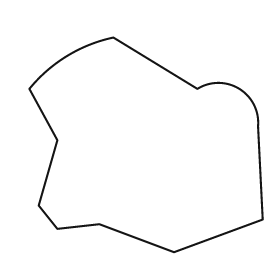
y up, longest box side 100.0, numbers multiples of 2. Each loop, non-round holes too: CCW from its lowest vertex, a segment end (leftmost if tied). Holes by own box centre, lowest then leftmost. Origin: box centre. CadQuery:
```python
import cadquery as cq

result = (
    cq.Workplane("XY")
    .moveTo(12.0, -46.0)
    .lineTo(50.0, -32.0)
    .lineTo(48.0, 8.0)
    .threePointArc((40.0, 24.0), (22.0, 24.0))
    .lineTo(-14.0, 46.0)
    .threePointArc((-34.0, 38.0), (-50.0, 24.0))
    .lineTo(-38.0, 2.0)
    .lineTo(-46.0, -26.0)
    .lineTo(-38.0, -36.0)
    .lineTo(-20.0, -34.0)
    .close()
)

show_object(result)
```